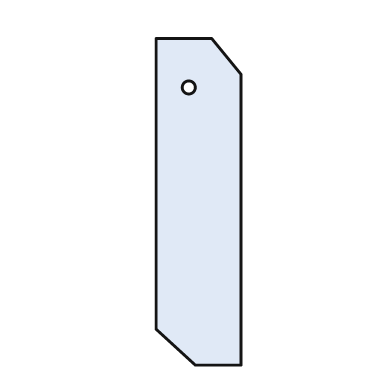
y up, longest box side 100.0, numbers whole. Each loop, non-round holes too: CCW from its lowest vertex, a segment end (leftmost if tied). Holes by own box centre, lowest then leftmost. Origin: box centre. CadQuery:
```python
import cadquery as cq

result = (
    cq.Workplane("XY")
    .moveTo(-1.0, -50.0)
    .lineTo(13.0, -50.0)
    .lineTo(13.0, 39.0)
    .lineTo(4.0, 50.0)
    .lineTo(-13.0, 50.0)
    .lineTo(-13.0, -39.0)
    .close()
    .moveTo(-3.0, 35.0)
    .circle(2.0)
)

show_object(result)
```